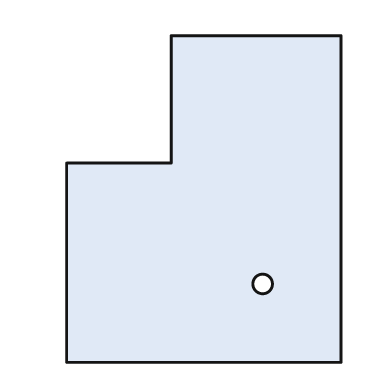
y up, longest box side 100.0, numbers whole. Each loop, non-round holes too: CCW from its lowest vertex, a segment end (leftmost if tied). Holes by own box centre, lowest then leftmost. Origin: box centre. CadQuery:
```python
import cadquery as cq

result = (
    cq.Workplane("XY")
    .moveTo(-42.0, -50.0)
    .lineTo(42.0, -50.0)
    .lineTo(42.0, 50.0)
    .lineTo(-10.0, 50.0)
    .lineTo(-10.0, 11.0)
    .lineTo(-42.0, 11.0)
    .close()
    .moveTo(18.0, -26.0)
    .circle(3.0)
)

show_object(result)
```